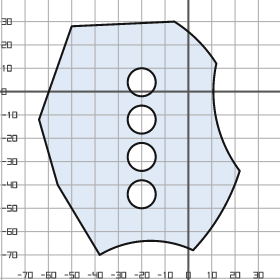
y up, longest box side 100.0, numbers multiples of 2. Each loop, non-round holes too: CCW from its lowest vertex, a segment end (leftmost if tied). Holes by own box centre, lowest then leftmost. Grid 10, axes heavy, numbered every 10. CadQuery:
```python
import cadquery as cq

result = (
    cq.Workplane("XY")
    .moveTo(-38.0, -70.0)
    .threePointArc((-18.0, -64.0), (2.0, -68.0))
    .threePointArc((14.0, -52.0), (22.0, -34.0))
    .threePointArc((12.0, -12.0), (12.0, 12.0))
    .threePointArc((4.0, 22.0), (-6.0, 30.0))
    .lineTo(-50.0, 28.0)
    .lineTo(-64.0, -12.0)
    .lineTo(-56.0, -40.0)
    .close()
    .moveTo(-20.0, -44.0)
    .circle(6.0)
    .moveTo(-20.0, -28.0)
    .circle(6.0)
    .moveTo(-20.0, -12.0)
    .circle(6.0)
    .moveTo(-20.0, 4.0)
    .circle(6.0)
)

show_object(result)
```